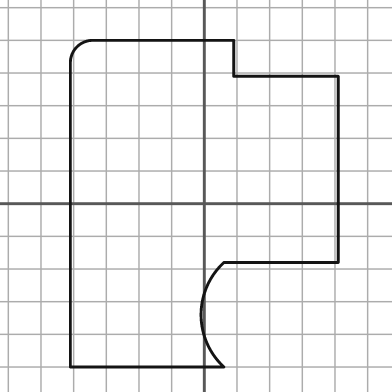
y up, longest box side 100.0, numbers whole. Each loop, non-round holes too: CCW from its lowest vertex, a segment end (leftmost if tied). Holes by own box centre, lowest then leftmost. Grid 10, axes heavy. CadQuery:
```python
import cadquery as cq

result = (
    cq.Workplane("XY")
    .moveTo(-41.0, -50.0)
    .lineTo(6.0, -50.0)
    .threePointArc((-1.0, -34.0), (6.0, -18.0))
    .lineTo(41.0, -18.0)
    .lineTo(41.0, 39.0)
    .lineTo(9.0, 39.0)
    .lineTo(9.0, 50.0)
    .lineTo(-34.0, 50.0)
    .threePointArc((-39.0, 48.0), (-41.0, 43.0))
    .close()
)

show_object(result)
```